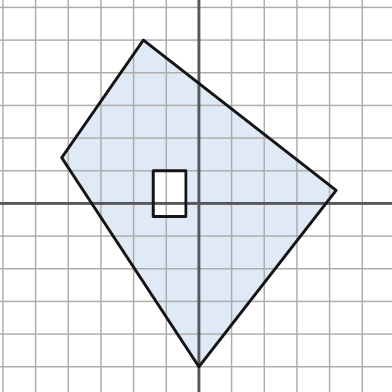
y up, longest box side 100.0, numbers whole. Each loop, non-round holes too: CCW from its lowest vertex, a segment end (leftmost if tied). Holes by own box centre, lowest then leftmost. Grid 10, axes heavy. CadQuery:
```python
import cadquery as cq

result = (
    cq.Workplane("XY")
    .moveTo(0.0, -50.0)
    .lineTo(42.0, 4.0)
    .lineTo(-17.0, 50.0)
    .lineTo(-42.0, 14.0)
    .close()
    .moveTo(-14.0, -4.0)
    .lineTo(-4.0, -4.0)
    .lineTo(-4.0, 10.0)
    .lineTo(-14.0, 10.0)
    .close()
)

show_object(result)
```